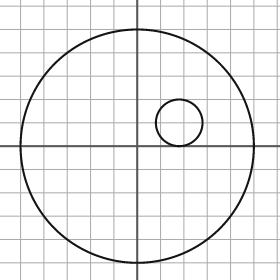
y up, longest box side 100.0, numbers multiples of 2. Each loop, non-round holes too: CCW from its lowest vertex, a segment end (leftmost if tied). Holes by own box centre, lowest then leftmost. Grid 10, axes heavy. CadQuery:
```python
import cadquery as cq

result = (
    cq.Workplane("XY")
    .moveTo(0.0, 0.0)
    .circle(50.0)
    .moveTo(18.0, 10.0)
    .circle(10.0)
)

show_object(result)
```